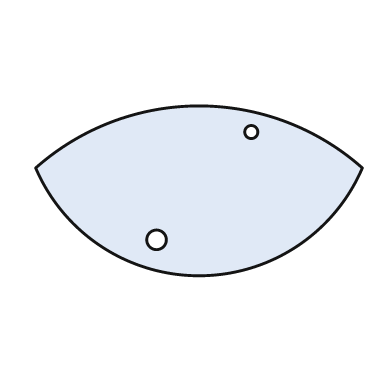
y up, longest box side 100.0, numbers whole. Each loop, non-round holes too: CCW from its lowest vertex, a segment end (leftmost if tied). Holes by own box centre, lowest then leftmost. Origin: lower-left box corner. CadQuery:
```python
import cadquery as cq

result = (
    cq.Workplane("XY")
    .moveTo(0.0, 33.0)
    .threePointArc((50.0, 0.0), (100.0, 33.0))
    .threePointArc((50.0, 52.0), (0.0, 33.0))
    .close()
    .moveTo(37.0, 11.0)
    .circle(3.0)
    .moveTo(66.0, 44.0)
    .circle(2.0)
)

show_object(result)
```